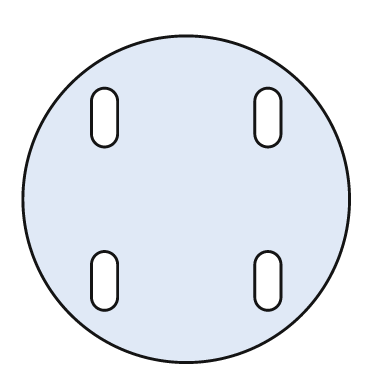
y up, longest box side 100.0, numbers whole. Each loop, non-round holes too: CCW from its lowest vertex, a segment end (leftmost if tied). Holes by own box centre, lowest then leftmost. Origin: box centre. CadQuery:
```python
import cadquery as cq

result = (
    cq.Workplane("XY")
    .moveTo(0.0, 0.0)
    .circle(50.0)
    .moveTo(-29.0, -30.0)
    .threePointArc((-25.0, -34.0), (-21.0, -30.0))
    .lineTo(-21.0, -20.0)
    .threePointArc((-25.0, -16.0), (-29.0, -20.0))
    .close()
    .moveTo(21.0, -30.0)
    .threePointArc((25.0, -34.0), (29.0, -30.0))
    .lineTo(29.0, -20.0)
    .threePointArc((25.0, -16.0), (21.0, -20.0))
    .close()
    .moveTo(-29.0, 20.0)
    .threePointArc((-25.0, 16.0), (-21.0, 20.0))
    .lineTo(-21.0, 30.0)
    .threePointArc((-25.0, 34.0), (-29.0, 30.0))
    .close()
    .moveTo(21.0, 20.0)
    .threePointArc((25.0, 16.0), (29.0, 20.0))
    .lineTo(29.0, 30.0)
    .threePointArc((25.0, 34.0), (21.0, 30.0))
    .close()
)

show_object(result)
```